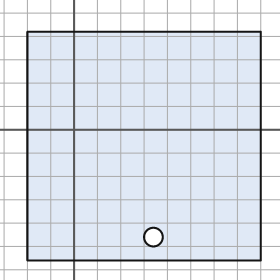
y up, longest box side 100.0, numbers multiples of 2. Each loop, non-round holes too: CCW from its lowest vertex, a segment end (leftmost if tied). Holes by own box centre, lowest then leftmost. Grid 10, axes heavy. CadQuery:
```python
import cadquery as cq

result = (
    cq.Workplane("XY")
    .moveTo(-20.0, -56.0)
    .lineTo(80.0, -56.0)
    .lineTo(80.0, 42.0)
    .lineTo(-20.0, 42.0)
    .close()
    .moveTo(34.0, -46.0)
    .circle(4.0)
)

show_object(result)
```